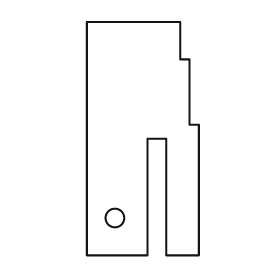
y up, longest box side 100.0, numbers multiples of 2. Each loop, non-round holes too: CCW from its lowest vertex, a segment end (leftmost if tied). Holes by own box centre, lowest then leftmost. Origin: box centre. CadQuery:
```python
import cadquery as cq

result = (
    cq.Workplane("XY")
    .moveTo(-24.0, -50.0)
    .lineTo(2.0, -50.0)
    .lineTo(2.0, 0.0)
    .lineTo(10.0, 0.0)
    .lineTo(10.0, -50.0)
    .lineTo(24.0, -50.0)
    .lineTo(24.0, 6.0)
    .lineTo(20.0, 6.0)
    .lineTo(20.0, 34.0)
    .lineTo(16.0, 34.0)
    .lineTo(16.0, 50.0)
    .lineTo(-24.0, 50.0)
    .close()
    .moveTo(-12.0, -34.0)
    .circle(4.0)
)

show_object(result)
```